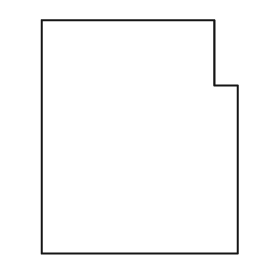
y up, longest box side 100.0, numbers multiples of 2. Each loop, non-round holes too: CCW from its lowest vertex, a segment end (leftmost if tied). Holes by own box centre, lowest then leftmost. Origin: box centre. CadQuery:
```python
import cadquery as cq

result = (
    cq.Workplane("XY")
    .moveTo(-42.0, -50.0)
    .lineTo(42.0, -50.0)
    .lineTo(42.0, 22.0)
    .lineTo(32.0, 22.0)
    .lineTo(32.0, 50.0)
    .lineTo(-42.0, 50.0)
    .close()
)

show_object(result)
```